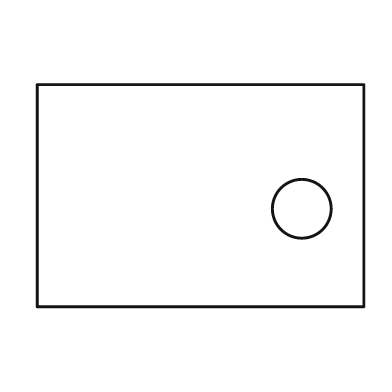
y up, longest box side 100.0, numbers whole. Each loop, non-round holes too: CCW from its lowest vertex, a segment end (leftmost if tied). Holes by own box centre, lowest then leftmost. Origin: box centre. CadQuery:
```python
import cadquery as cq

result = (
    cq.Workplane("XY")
    .moveTo(-50.0, -34.0)
    .lineTo(50.0, -34.0)
    .lineTo(50.0, 34.0)
    .lineTo(-50.0, 34.0)
    .close()
    .moveTo(31.0, -4.0)
    .circle(9.0)
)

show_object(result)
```